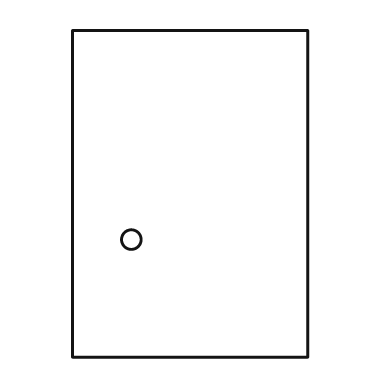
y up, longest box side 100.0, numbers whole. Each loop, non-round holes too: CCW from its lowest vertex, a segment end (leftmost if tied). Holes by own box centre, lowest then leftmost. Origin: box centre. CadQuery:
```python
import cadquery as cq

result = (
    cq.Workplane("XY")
    .moveTo(-36.0, -50.0)
    .lineTo(36.0, -50.0)
    .lineTo(36.0, 50.0)
    .lineTo(-36.0, 50.0)
    .close()
    .moveTo(-18.0, -14.0)
    .circle(3.0)
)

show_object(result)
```